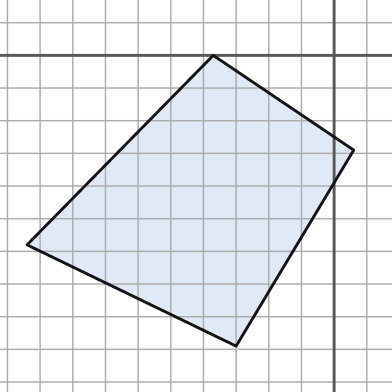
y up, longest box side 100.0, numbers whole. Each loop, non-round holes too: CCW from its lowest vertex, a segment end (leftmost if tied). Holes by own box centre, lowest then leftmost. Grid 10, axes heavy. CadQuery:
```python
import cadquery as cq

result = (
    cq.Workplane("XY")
    .moveTo(-30.0, -89.0)
    .lineTo(6.0, -29.0)
    .lineTo(-37.0, 0.0)
    .lineTo(-94.0, -58.0)
    .close()
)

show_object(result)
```